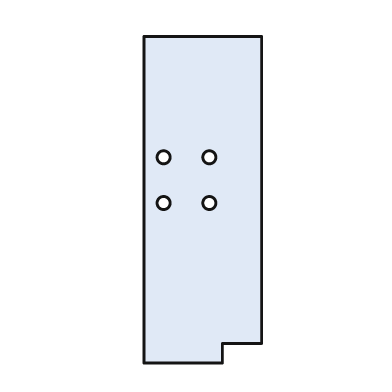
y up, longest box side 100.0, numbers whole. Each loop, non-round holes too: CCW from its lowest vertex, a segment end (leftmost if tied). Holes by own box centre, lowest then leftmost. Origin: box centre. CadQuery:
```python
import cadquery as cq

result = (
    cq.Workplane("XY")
    .moveTo(-18.0, -50.0)
    .lineTo(6.0, -50.0)
    .lineTo(6.0, -44.0)
    .lineTo(18.0, -44.0)
    .lineTo(18.0, 50.0)
    .lineTo(-18.0, 50.0)
    .close()
    .moveTo(-12.0, -1.0)
    .circle(2.0)
    .moveTo(2.0, -1.0)
    .circle(2.0)
    .moveTo(-12.0, 13.0)
    .circle(2.0)
    .moveTo(2.0, 13.0)
    .circle(2.0)
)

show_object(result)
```